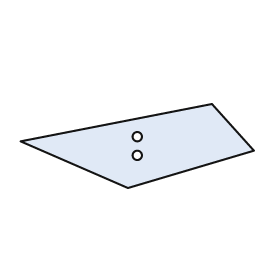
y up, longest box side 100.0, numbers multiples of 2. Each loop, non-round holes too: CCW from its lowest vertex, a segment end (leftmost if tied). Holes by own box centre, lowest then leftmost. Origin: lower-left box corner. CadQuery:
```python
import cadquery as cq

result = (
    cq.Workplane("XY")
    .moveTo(46.0, 0.0)
    .lineTo(100.0, 16.0)
    .lineTo(82.0, 36.0)
    .lineTo(0.0, 20.0)
    .close()
    .moveTo(50.0, 14.0)
    .circle(2.0)
    .moveTo(50.0, 22.0)
    .circle(2.0)
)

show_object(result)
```